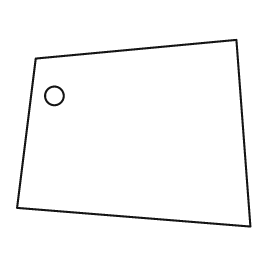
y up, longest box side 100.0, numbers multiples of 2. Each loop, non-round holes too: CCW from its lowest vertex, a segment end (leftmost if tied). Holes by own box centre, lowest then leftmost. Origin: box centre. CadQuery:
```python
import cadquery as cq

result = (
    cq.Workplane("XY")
    .moveTo(50.0, -40.0)
    .lineTo(44.0, 40.0)
    .lineTo(-42.0, 32.0)
    .lineTo(-50.0, -32.0)
    .close()
    .moveTo(-34.0, 16.0)
    .circle(4.0)
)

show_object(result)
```